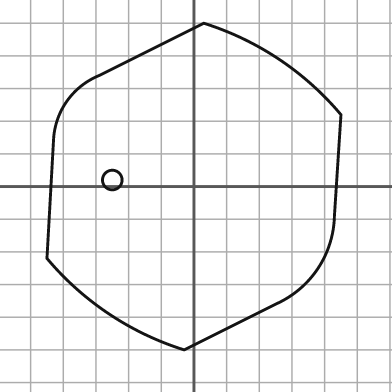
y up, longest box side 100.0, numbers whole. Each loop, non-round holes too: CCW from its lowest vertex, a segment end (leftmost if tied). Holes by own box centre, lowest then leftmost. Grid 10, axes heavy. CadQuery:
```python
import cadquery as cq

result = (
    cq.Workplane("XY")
    .moveTo(-3.0, -50.0)
    .lineTo(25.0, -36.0)
    .threePointArc((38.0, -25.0), (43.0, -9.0))
    .lineTo(45.0, 22.0)
    .threePointArc((26.0, 39.0), (3.0, 50.0))
    .lineTo(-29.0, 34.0)
    .threePointArc((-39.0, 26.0), (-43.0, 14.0))
    .lineTo(-45.0, -22.0)
    .threePointArc((-26.0, -39.0), (-3.0, -50.0))
    .close()
    .moveTo(-25.0, 2.0)
    .circle(3.0)
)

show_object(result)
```